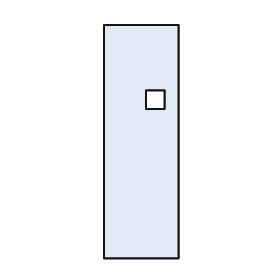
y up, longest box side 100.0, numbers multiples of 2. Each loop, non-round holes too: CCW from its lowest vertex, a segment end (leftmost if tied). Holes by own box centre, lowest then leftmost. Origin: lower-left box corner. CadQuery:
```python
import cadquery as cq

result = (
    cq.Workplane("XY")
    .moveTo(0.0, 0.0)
    .lineTo(32.0, 0.0)
    .lineTo(32.0, 100.0)
    .lineTo(0.0, 100.0)
    .close()
    .moveTo(18.0, 64.0)
    .lineTo(26.0, 64.0)
    .lineTo(26.0, 72.0)
    .lineTo(18.0, 72.0)
    .close()
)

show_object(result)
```